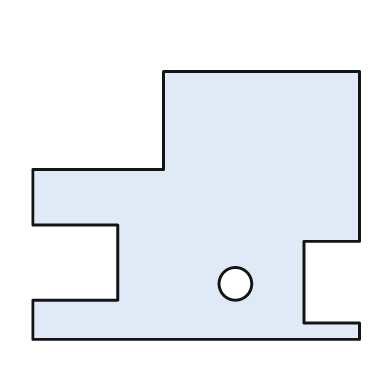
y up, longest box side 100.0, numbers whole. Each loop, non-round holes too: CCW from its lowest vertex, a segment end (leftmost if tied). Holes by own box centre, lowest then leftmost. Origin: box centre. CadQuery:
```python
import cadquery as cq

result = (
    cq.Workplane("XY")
    .moveTo(-50.0, -41.0)
    .lineTo(50.0, -41.0)
    .lineTo(50.0, -36.0)
    .lineTo(33.0, -36.0)
    .lineTo(33.0, -11.0)
    .lineTo(50.0, -11.0)
    .lineTo(50.0, 41.0)
    .lineTo(-10.0, 41.0)
    .lineTo(-10.0, 11.0)
    .lineTo(-50.0, 11.0)
    .lineTo(-50.0, -6.0)
    .lineTo(-24.0, -6.0)
    .lineTo(-24.0, -29.0)
    .lineTo(-50.0, -29.0)
    .close()
    .moveTo(12.0, -24.0)
    .circle(5.0)
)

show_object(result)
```